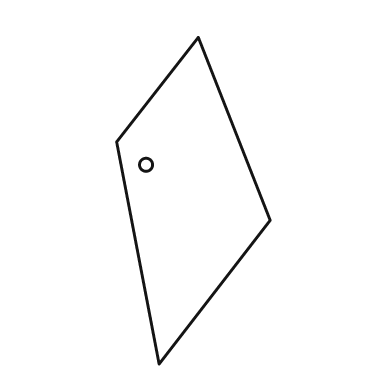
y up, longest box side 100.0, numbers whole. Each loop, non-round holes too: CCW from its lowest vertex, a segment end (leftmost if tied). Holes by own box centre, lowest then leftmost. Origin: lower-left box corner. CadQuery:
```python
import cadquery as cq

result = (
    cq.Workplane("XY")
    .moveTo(13.0, 0.0)
    .lineTo(47.0, 44.0)
    .lineTo(25.0, 100.0)
    .lineTo(0.0, 68.0)
    .close()
    .moveTo(9.0, 61.0)
    .circle(2.0)
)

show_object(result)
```